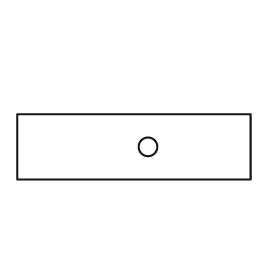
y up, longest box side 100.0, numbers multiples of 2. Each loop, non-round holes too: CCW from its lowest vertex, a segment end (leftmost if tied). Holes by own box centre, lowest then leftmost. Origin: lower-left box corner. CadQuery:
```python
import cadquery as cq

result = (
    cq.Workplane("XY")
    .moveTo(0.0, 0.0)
    .lineTo(100.0, 0.0)
    .lineTo(100.0, 28.0)
    .lineTo(0.0, 28.0)
    .close()
    .moveTo(56.0, 14.0)
    .circle(4.0)
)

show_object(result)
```